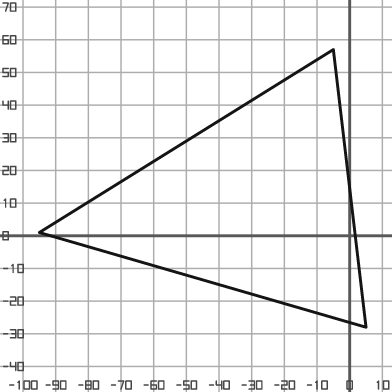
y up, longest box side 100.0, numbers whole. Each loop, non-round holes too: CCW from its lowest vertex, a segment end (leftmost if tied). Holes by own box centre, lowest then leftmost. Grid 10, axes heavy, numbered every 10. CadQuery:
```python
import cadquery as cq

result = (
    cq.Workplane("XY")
    .moveTo(5.0, -28.0)
    .lineTo(-5.0, 57.0)
    .lineTo(-95.0, 1.0)
    .close()
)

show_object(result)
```